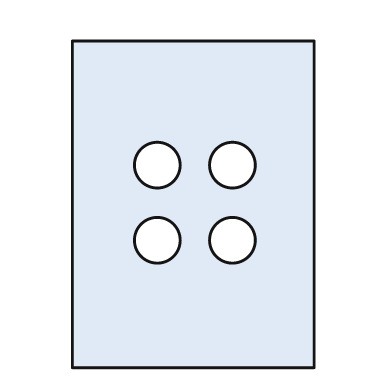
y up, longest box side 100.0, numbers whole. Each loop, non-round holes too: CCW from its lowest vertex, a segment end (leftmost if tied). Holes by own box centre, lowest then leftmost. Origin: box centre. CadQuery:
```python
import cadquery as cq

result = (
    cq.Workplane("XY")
    .moveTo(-37.0, -50.0)
    .lineTo(37.0, -50.0)
    .lineTo(37.0, 50.0)
    .lineTo(-37.0, 50.0)
    .close()
    .moveTo(-11.0, -11.0)
    .circle(7.0)
    .moveTo(12.0, -11.0)
    .circle(7.0)
    .moveTo(-11.0, 12.0)
    .circle(7.0)
    .moveTo(12.0, 12.0)
    .circle(7.0)
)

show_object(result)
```